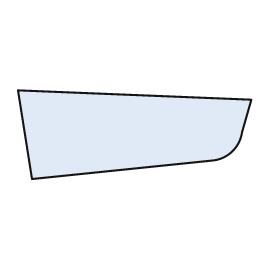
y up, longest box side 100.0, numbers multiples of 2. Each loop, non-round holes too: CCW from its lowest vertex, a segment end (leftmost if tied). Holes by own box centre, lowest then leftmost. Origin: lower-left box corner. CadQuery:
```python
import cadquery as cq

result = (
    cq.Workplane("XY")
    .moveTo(6.0, 0.0)
    .lineTo(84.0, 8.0)
    .threePointArc((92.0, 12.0), (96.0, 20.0))
    .lineTo(100.0, 34.0)
    .lineTo(0.0, 38.0)
    .close()
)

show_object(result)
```